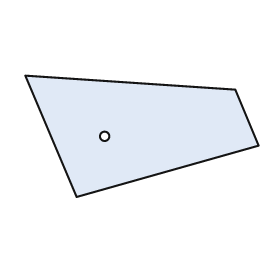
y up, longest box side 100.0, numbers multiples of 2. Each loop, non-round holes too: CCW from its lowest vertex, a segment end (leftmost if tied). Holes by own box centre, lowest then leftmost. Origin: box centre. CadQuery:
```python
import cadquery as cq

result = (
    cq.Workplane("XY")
    .moveTo(-28.0, -26.0)
    .lineTo(50.0, -4.0)
    .lineTo(40.0, 20.0)
    .lineTo(-50.0, 26.0)
    .close()
    .moveTo(-16.0, 0.0)
    .circle(2.0)
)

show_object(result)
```